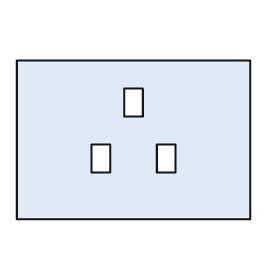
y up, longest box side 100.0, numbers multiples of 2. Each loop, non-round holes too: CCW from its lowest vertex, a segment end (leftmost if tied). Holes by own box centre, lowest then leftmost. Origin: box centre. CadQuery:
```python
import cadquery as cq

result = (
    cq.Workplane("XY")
    .moveTo(-50.0, -34.0)
    .lineTo(50.0, -34.0)
    .lineTo(50.0, 34.0)
    .lineTo(-50.0, 34.0)
    .close()
    .moveTo(-18.0, -14.0)
    .lineTo(-10.0, -14.0)
    .lineTo(-10.0, -2.0)
    .lineTo(-18.0, -2.0)
    .close()
    .moveTo(10.0, -14.0)
    .lineTo(18.0, -14.0)
    .lineTo(18.0, -2.0)
    .lineTo(10.0, -2.0)
    .close()
    .moveTo(-4.0, 10.0)
    .lineTo(4.0, 10.0)
    .lineTo(4.0, 22.0)
    .lineTo(-4.0, 22.0)
    .close()
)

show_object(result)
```